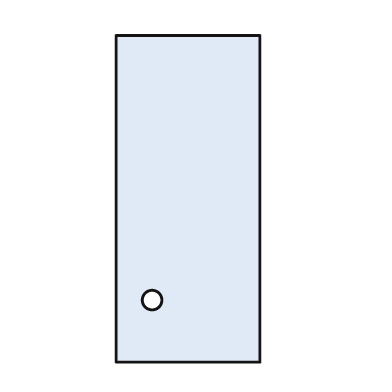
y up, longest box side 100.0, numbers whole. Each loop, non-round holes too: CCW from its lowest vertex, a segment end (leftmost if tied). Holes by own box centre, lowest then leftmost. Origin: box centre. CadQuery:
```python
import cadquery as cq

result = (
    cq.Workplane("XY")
    .moveTo(-22.0, -50.0)
    .lineTo(22.0, -50.0)
    .lineTo(22.0, 50.0)
    .lineTo(-22.0, 50.0)
    .close()
    .moveTo(-11.0, -31.0)
    .circle(3.0)
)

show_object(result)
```